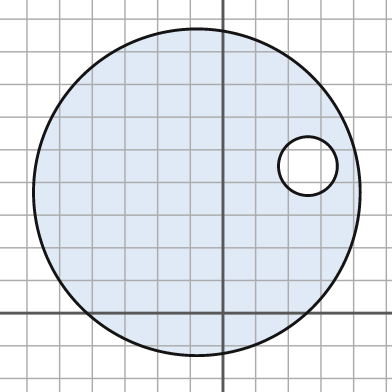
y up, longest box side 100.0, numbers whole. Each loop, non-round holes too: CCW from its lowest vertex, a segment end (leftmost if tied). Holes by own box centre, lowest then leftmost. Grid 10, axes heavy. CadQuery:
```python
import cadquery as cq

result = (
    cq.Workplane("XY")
    .moveTo(-8.0, 37.0)
    .circle(50.0)
    .moveTo(26.0, 45.0)
    .circle(9.0)
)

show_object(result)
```